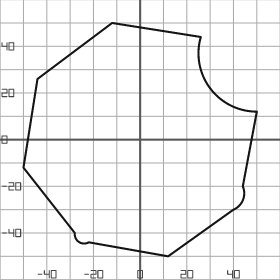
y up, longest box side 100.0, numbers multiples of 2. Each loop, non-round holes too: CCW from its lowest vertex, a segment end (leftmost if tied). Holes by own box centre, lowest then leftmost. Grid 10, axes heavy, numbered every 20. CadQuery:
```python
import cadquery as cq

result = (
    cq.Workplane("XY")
    .moveTo(12.0, -50.0)
    .lineTo(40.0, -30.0)
    .threePointArc((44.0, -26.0), (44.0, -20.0))
    .lineTo(50.0, 12.0)
    .threePointArc((30.0, 22.0), (26.0, 44.0))
    .lineTo(-12.0, 50.0)
    .lineTo(-44.0, 26.0)
    .lineTo(-50.0, -12.0)
    .lineTo(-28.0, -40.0)
    .threePointArc((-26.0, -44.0), (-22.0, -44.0))
    .close()
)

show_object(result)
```